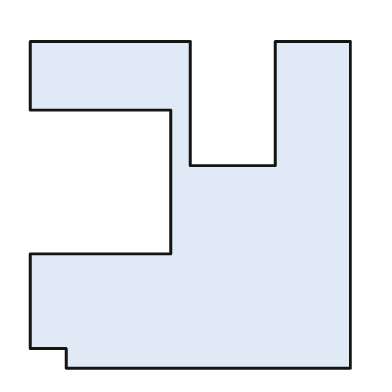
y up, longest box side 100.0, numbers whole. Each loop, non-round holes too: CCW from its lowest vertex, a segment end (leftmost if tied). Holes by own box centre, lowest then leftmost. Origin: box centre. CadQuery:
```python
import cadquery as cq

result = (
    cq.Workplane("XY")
    .moveTo(-38.0, -50.0)
    .lineTo(49.0, -50.0)
    .lineTo(49.0, 50.0)
    .lineTo(26.0, 50.0)
    .lineTo(26.0, 12.0)
    .lineTo(0.0, 12.0)
    .lineTo(0.0, 50.0)
    .lineTo(-49.0, 50.0)
    .lineTo(-49.0, 29.0)
    .lineTo(-6.0, 29.0)
    .lineTo(-6.0, -15.0)
    .lineTo(-49.0, -15.0)
    .lineTo(-49.0, -44.0)
    .lineTo(-38.0, -44.0)
    .close()
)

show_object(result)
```